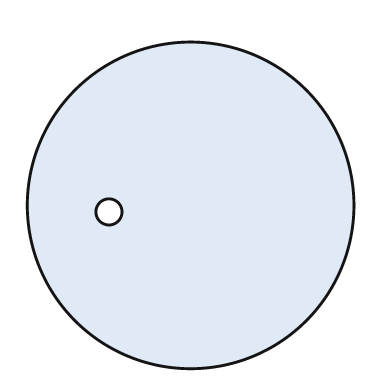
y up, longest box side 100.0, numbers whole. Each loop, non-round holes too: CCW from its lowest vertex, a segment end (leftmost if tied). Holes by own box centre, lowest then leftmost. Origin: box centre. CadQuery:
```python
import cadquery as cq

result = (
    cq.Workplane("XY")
    .moveTo(0.0, 0.0)
    .circle(50.0)
    .moveTo(-25.0, -2.0)
    .circle(4.0)
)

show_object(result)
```